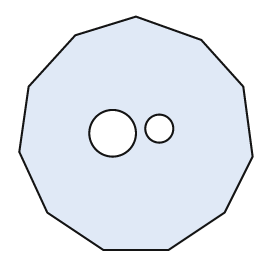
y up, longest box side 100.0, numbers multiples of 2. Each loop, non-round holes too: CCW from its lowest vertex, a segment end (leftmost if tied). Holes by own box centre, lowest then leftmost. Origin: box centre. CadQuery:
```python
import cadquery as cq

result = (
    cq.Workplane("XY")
    .moveTo(-14.0, -50.0)
    .lineTo(14.0, -50.0)
    .lineTo(38.0, -34.0)
    .lineTo(50.0, -10.0)
    .lineTo(46.0, 20.0)
    .lineTo(28.0, 40.0)
    .lineTo(0.0, 50.0)
    .lineTo(-26.0, 42.0)
    .lineTo(-46.0, 20.0)
    .lineTo(-50.0, -8.0)
    .lineTo(-38.0, -34.0)
    .close()
    .moveTo(-10.0, 0.0)
    .circle(10.0)
    .moveTo(10.0, 2.0)
    .circle(6.0)
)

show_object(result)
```